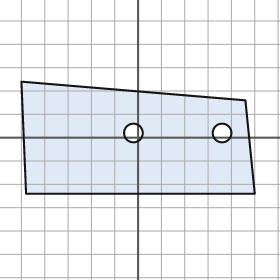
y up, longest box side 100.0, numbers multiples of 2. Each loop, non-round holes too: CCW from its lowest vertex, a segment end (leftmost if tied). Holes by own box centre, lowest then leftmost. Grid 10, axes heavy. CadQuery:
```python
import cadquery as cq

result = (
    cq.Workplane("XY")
    .moveTo(-48.0, -24.0)
    .lineTo(50.0, -24.0)
    .lineTo(46.0, 16.0)
    .lineTo(-50.0, 24.0)
    .close()
    .moveTo(-2.0, 2.0)
    .circle(4.0)
    .moveTo(36.0, 2.0)
    .circle(4.0)
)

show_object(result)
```